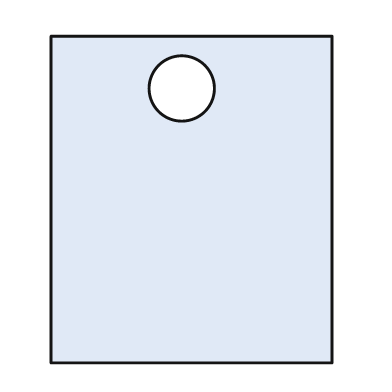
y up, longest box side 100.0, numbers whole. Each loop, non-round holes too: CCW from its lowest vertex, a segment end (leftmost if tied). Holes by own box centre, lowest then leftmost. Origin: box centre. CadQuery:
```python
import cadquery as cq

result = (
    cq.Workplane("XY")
    .moveTo(-43.0, -50.0)
    .lineTo(43.0, -50.0)
    .lineTo(43.0, 50.0)
    .lineTo(-43.0, 50.0)
    .close()
    .moveTo(-3.0, 34.0)
    .circle(10.0)
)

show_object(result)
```